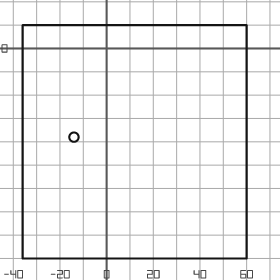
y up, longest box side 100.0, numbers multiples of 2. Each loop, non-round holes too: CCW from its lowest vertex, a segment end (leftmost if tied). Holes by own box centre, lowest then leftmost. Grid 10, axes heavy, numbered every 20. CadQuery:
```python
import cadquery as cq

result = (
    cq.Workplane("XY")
    .moveTo(-36.0, -90.0)
    .lineTo(60.0, -90.0)
    .lineTo(60.0, 10.0)
    .lineTo(-36.0, 10.0)
    .close()
    .moveTo(-14.0, -38.0)
    .circle(2.0)
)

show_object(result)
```